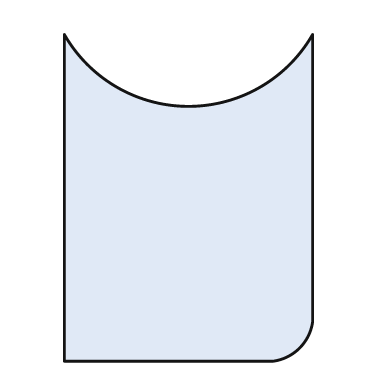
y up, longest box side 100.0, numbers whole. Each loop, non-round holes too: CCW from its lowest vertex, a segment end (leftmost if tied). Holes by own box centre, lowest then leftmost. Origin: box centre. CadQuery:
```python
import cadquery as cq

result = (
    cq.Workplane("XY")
    .moveTo(-38.0, -50.0)
    .lineTo(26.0, -50.0)
    .threePointArc((34.0, -46.0), (38.0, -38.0))
    .lineTo(38.0, 50.0)
    .threePointArc((0.0, 28.0), (-38.0, 50.0))
    .close()
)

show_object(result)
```